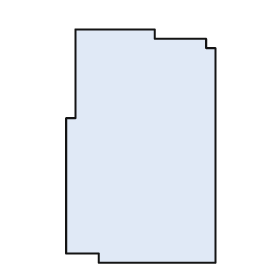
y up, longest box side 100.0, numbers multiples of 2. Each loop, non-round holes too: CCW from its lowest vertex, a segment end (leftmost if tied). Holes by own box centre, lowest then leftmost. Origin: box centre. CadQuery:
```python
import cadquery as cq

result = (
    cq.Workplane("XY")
    .moveTo(-18.0, -50.0)
    .lineTo(32.0, -50.0)
    .lineTo(32.0, 42.0)
    .lineTo(28.0, 42.0)
    .lineTo(28.0, 46.0)
    .lineTo(6.0, 46.0)
    .lineTo(6.0, 50.0)
    .lineTo(-28.0, 50.0)
    .lineTo(-28.0, 12.0)
    .lineTo(-32.0, 12.0)
    .lineTo(-32.0, -46.0)
    .lineTo(-18.0, -46.0)
    .close()
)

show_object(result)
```